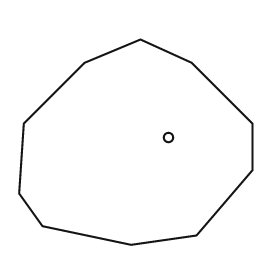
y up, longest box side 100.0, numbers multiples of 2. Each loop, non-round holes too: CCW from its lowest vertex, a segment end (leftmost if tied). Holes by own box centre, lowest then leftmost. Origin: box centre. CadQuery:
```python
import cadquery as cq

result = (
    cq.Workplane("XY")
    .moveTo(-2.0, -44.0)
    .lineTo(26.0, -40.0)
    .lineTo(50.0, -12.0)
    .lineTo(50.0, 8.0)
    .lineTo(24.0, 34.0)
    .lineTo(2.0, 44.0)
    .lineTo(-22.0, 34.0)
    .lineTo(-48.0, 8.0)
    .lineTo(-50.0, -22.0)
    .lineTo(-40.0, -36.0)
    .close()
    .moveTo(14.0, 2.0)
    .circle(2.0)
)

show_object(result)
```